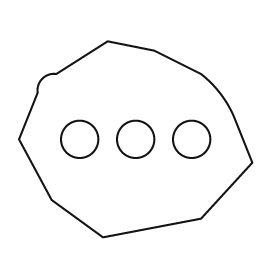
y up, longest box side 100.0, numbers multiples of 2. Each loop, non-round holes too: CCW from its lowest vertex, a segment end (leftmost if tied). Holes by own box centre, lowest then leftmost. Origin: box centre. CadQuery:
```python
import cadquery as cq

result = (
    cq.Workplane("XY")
    .moveTo(-14.0, -42.0)
    .lineTo(28.0, -34.0)
    .lineTo(50.0, -10.0)
    .lineTo(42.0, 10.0)
    .threePointArc((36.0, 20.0), (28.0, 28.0))
    .lineTo(8.0, 38.0)
    .lineTo(-12.0, 42.0)
    .lineTo(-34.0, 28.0)
    .threePointArc((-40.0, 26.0), (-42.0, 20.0))
    .lineTo(-50.0, 0.0)
    .lineTo(-36.0, -26.0)
    .close()
    .moveTo(-24.0, 0.0)
    .circle(8.0)
    .moveTo(0.0, 0.0)
    .circle(8.0)
    .moveTo(24.0, 0.0)
    .circle(8.0)
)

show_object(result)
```